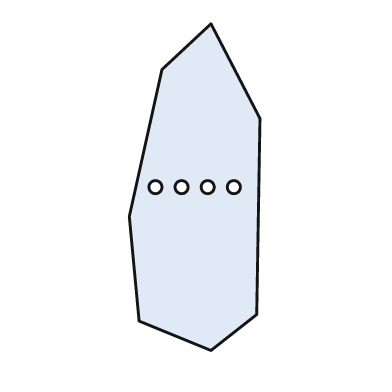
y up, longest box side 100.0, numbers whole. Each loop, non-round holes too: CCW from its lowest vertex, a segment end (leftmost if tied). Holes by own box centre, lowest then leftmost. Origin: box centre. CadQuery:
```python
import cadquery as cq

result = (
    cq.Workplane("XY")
    .moveTo(5.0, -50.0)
    .lineTo(19.0, -39.0)
    .lineTo(20.0, 21.0)
    .lineTo(5.0, 50.0)
    .lineTo(-10.0, 36.0)
    .lineTo(-20.0, -9.0)
    .lineTo(-17.0, -41.0)
    .close()
    .moveTo(-12.0, 0.0)
    .circle(2.0)
    .moveTo(-4.0, 0.0)
    .circle(2.0)
    .moveTo(4.0, 0.0)
    .circle(2.0)
    .moveTo(12.0, 0.0)
    .circle(2.0)
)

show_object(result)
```